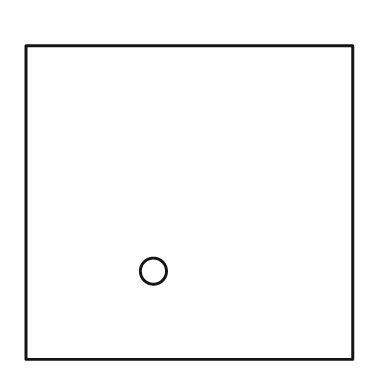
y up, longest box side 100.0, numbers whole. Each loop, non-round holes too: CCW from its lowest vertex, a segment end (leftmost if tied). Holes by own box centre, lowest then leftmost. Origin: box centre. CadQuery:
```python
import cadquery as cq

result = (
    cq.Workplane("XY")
    .moveTo(-50.0, -48.0)
    .lineTo(50.0, -48.0)
    .lineTo(50.0, 48.0)
    .lineTo(-50.0, 48.0)
    .close()
    .moveTo(-11.0, -21.0)
    .circle(4.0)
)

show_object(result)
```